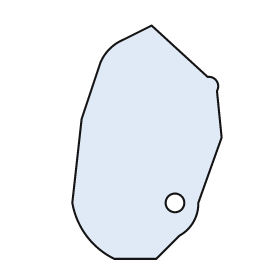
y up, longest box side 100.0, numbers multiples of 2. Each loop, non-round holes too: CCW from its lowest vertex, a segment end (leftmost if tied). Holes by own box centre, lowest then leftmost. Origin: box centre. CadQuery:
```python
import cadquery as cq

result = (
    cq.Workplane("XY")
    .moveTo(-14.0, -50.0)
    .lineTo(4.0, -50.0)
    .lineTo(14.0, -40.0)
    .threePointArc((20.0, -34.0), (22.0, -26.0))
    .lineTo(32.0, 2.0)
    .lineTo(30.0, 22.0)
    .threePointArc((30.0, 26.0), (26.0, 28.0))
    .lineTo(2.0, 50.0)
    .lineTo(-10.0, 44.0)
    .threePointArc((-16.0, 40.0), (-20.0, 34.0))
    .lineTo(-28.0, 10.0)
    .lineTo(-32.0, -26.0)
    .threePointArc((-26.0, -40.0), (-14.0, -50.0))
    .close()
    .moveTo(12.0, -26.0)
    .circle(4.0)
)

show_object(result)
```